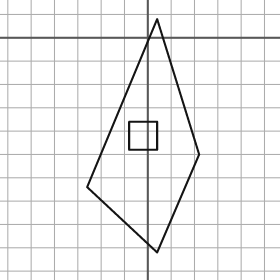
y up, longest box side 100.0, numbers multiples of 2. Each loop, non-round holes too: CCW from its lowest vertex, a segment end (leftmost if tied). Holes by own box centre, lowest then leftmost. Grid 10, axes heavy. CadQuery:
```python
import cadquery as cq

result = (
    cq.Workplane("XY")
    .moveTo(4.0, -92.0)
    .lineTo(22.0, -50.0)
    .lineTo(4.0, 8.0)
    .lineTo(-26.0, -64.0)
    .close()
    .moveTo(-8.0, -48.0)
    .lineTo(4.0, -48.0)
    .lineTo(4.0, -36.0)
    .lineTo(-8.0, -36.0)
    .close()
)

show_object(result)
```